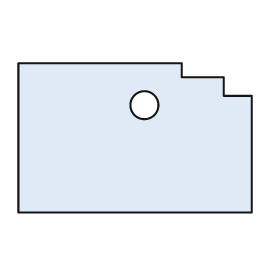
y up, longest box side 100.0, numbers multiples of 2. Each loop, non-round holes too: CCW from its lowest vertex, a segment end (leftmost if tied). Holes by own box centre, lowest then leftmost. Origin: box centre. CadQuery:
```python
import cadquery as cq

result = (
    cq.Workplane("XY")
    .moveTo(-50.0, -32.0)
    .lineTo(50.0, -32.0)
    .lineTo(50.0, 18.0)
    .lineTo(38.0, 18.0)
    .lineTo(38.0, 26.0)
    .lineTo(20.0, 26.0)
    .lineTo(20.0, 32.0)
    .lineTo(-50.0, 32.0)
    .close()
    .moveTo(4.0, 14.0)
    .circle(6.0)
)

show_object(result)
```